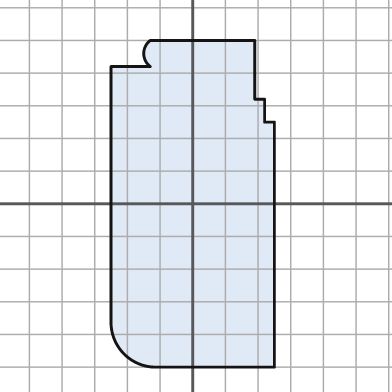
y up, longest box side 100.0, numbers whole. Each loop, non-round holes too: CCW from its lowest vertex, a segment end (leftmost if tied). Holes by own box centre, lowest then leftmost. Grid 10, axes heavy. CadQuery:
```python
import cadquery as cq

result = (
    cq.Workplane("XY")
    .moveTo(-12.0, -50.0)
    .lineTo(25.0, -50.0)
    .lineTo(25.0, 25.0)
    .lineTo(22.0, 25.0)
    .lineTo(22.0, 32.0)
    .lineTo(19.0, 32.0)
    .lineTo(19.0, 50.0)
    .lineTo(-13.0, 50.0)
    .threePointArc((-15.0, 46.0), (-13.0, 42.0))
    .lineTo(-25.0, 42.0)
    .lineTo(-25.0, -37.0)
    .threePointArc((-21.0, -46.0), (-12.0, -50.0))
    .close()
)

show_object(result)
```